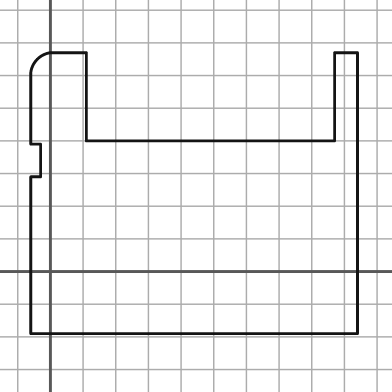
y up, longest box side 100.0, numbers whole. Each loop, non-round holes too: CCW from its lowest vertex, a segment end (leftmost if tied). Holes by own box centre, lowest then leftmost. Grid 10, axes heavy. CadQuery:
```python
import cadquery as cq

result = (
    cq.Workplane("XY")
    .moveTo(-6.0, -19.0)
    .lineTo(94.0, -19.0)
    .lineTo(94.0, 67.0)
    .lineTo(87.0, 67.0)
    .lineTo(87.0, 40.0)
    .lineTo(11.0, 40.0)
    .lineTo(11.0, 67.0)
    .lineTo(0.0, 67.0)
    .threePointArc((-4.0, 65.0), (-6.0, 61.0))
    .lineTo(-6.0, 39.0)
    .lineTo(-3.0, 39.0)
    .lineTo(-3.0, 29.0)
    .lineTo(-6.0, 29.0)
    .close()
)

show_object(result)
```